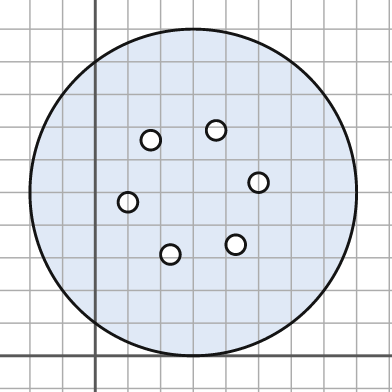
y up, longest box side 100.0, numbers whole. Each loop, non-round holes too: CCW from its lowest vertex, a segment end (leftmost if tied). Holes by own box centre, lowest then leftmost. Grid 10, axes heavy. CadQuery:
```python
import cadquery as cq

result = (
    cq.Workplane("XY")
    .moveTo(30.0, 50.0)
    .circle(50.0)
    .moveTo(23.0, 31.0)
    .circle(3.0)
    .moveTo(43.0, 34.0)
    .circle(3.0)
    .moveTo(10.0, 47.0)
    .circle(3.0)
    .moveTo(50.0, 53.0)
    .circle(3.0)
    .moveTo(17.0, 66.0)
    .circle(3.0)
    .moveTo(37.0, 69.0)
    .circle(3.0)
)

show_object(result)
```